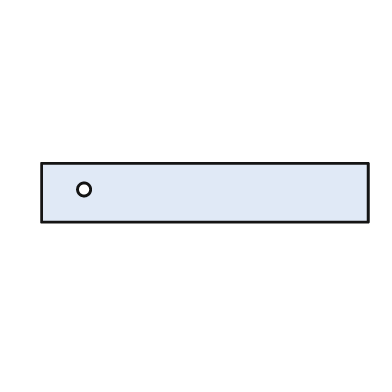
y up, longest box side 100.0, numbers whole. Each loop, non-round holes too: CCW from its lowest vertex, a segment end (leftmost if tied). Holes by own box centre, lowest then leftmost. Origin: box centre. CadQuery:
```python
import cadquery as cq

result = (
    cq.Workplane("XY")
    .moveTo(-50.0, -9.0)
    .lineTo(50.0, -9.0)
    .lineTo(50.0, 9.0)
    .lineTo(-50.0, 9.0)
    .close()
    .moveTo(-37.0, 1.0)
    .circle(2.0)
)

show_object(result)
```